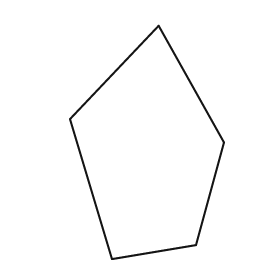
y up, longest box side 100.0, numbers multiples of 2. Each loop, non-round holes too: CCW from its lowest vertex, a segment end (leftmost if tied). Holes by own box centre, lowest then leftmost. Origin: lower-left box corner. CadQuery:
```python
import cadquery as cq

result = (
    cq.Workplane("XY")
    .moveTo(18.0, 0.0)
    .lineTo(54.0, 6.0)
    .lineTo(66.0, 50.0)
    .lineTo(38.0, 100.0)
    .lineTo(0.0, 60.0)
    .close()
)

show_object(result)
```